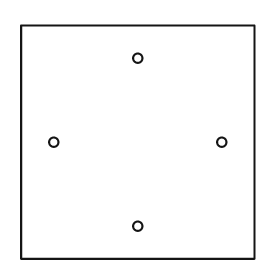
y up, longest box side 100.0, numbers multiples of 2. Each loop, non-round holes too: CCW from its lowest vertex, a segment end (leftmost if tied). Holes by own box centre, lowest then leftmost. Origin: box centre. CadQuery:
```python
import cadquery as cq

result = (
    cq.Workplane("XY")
    .moveTo(-50.0, -50.0)
    .lineTo(50.0, -50.0)
    .lineTo(50.0, 50.0)
    .lineTo(-50.0, 50.0)
    .close()
    .moveTo(0.0, -36.0)
    .circle(2.0)
    .moveTo(-36.0, 0.0)
    .circle(2.0)
    .moveTo(36.0, 0.0)
    .circle(2.0)
    .moveTo(0.0, 36.0)
    .circle(2.0)
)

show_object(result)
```